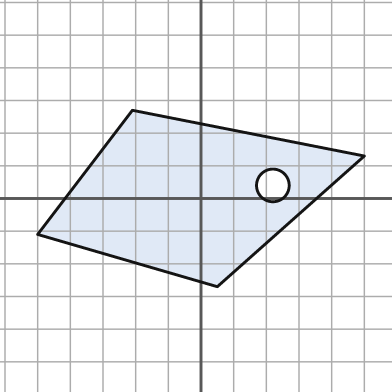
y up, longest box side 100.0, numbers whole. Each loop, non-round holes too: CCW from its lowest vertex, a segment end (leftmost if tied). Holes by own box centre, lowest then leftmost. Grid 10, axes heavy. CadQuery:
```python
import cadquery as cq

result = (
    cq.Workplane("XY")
    .moveTo(5.0, -27.0)
    .lineTo(50.0, 13.0)
    .lineTo(-21.0, 27.0)
    .lineTo(-50.0, -11.0)
    .close()
    .moveTo(22.0, 4.0)
    .circle(5.0)
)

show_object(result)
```